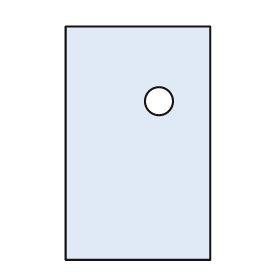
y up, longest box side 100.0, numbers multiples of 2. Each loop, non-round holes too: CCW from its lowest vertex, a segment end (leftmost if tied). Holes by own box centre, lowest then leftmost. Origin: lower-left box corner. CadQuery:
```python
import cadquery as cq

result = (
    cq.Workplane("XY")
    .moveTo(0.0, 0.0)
    .lineTo(62.0, 0.0)
    .lineTo(62.0, 100.0)
    .lineTo(0.0, 100.0)
    .close()
    .moveTo(40.0, 68.0)
    .circle(6.0)
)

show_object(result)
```